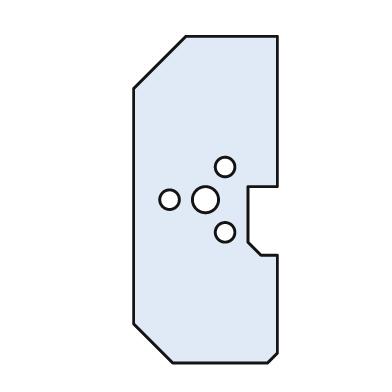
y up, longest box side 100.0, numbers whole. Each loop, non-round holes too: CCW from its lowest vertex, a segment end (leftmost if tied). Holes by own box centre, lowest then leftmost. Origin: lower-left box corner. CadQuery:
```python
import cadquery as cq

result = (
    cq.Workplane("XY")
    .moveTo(12.0, 0.0)
    .lineTo(41.0, 0.0)
    .lineTo(44.0, 3.0)
    .lineTo(44.0, 33.0)
    .lineTo(39.0, 33.0)
    .lineTo(35.0, 37.0)
    .lineTo(35.0, 54.0)
    .lineTo(44.0, 54.0)
    .lineTo(44.0, 100.0)
    .lineTo(16.0, 100.0)
    .lineTo(0.0, 84.0)
    .lineTo(0.0, 12.0)
    .close()
    .moveTo(28.0, 40.0)
    .circle(3.0)
    .moveTo(11.0, 50.0)
    .circle(3.0)
    .moveTo(22.0, 50.0)
    .circle(4.0)
    .moveTo(28.0, 60.0)
    .circle(3.0)
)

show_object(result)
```